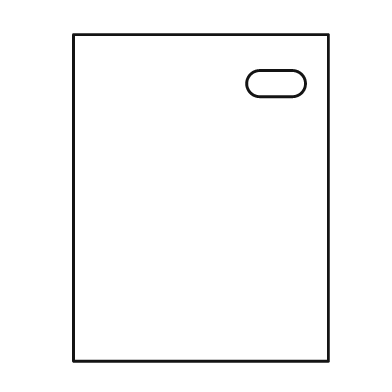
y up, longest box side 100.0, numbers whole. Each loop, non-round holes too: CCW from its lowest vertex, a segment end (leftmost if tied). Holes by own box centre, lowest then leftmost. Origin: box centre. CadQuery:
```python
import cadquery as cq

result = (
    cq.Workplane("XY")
    .moveTo(-39.0, -50.0)
    .lineTo(39.0, -50.0)
    .lineTo(39.0, 50.0)
    .lineTo(-39.0, 50.0)
    .close()
    .moveTo(18.0, 31.0)
    .lineTo(28.0, 31.0)
    .threePointArc((32.0, 35.0), (28.0, 39.0))
    .lineTo(18.0, 39.0)
    .threePointArc((14.0, 35.0), (18.0, 31.0))
    .close()
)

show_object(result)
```